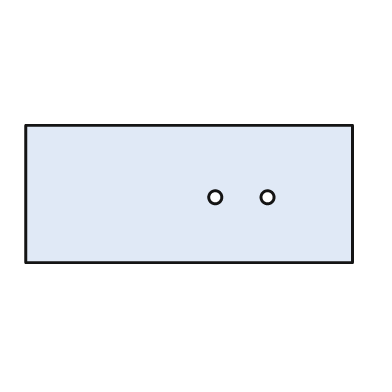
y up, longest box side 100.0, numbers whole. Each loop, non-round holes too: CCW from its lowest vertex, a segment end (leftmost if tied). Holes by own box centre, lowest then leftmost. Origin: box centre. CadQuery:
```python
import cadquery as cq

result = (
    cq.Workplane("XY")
    .moveTo(-50.0, -21.0)
    .lineTo(50.0, -21.0)
    .lineTo(50.0, 21.0)
    .lineTo(-50.0, 21.0)
    .close()
    .moveTo(8.0, -1.0)
    .circle(2.0)
    .moveTo(24.0, -1.0)
    .circle(2.0)
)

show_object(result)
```